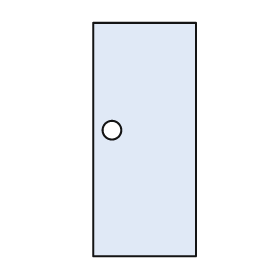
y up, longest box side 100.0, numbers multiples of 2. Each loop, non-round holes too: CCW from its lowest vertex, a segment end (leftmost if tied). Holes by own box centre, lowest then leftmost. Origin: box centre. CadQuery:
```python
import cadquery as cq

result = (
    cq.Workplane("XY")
    .moveTo(-22.0, -50.0)
    .lineTo(22.0, -50.0)
    .lineTo(22.0, 50.0)
    .lineTo(-22.0, 50.0)
    .close()
    .moveTo(-14.0, 4.0)
    .circle(4.0)
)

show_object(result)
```